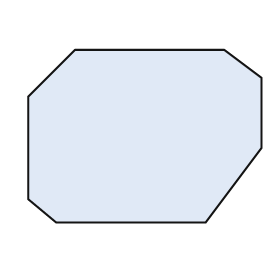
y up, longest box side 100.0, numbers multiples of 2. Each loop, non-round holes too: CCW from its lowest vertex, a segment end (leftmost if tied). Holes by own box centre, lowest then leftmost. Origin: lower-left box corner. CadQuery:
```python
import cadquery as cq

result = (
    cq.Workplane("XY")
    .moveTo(12.0, 0.0)
    .lineTo(76.0, 0.0)
    .lineTo(100.0, 32.0)
    .lineTo(100.0, 62.0)
    .lineTo(84.0, 74.0)
    .lineTo(20.0, 74.0)
    .lineTo(0.0, 54.0)
    .lineTo(0.0, 10.0)
    .close()
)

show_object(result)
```